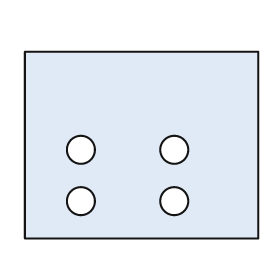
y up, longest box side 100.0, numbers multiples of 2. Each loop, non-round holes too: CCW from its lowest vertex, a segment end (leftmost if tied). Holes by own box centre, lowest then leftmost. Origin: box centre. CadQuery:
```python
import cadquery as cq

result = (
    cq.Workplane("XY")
    .moveTo(-50.0, -40.0)
    .lineTo(50.0, -40.0)
    .lineTo(50.0, 40.0)
    .lineTo(-50.0, 40.0)
    .close()
    .moveTo(-26.0, -24.0)
    .circle(6.0)
    .moveTo(14.0, -24.0)
    .circle(6.0)
    .moveTo(-26.0, -2.0)
    .circle(6.0)
    .moveTo(14.0, -2.0)
    .circle(6.0)
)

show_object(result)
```